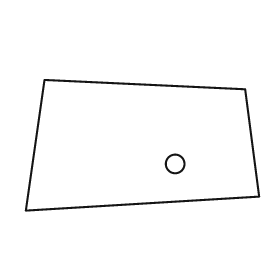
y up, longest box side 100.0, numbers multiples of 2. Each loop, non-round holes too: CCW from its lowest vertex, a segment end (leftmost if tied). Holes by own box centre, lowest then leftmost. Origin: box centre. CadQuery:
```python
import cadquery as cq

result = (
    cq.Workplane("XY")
    .moveTo(-50.0, -28.0)
    .lineTo(50.0, -22.0)
    .lineTo(44.0, 24.0)
    .lineTo(-42.0, 28.0)
    .close()
    .moveTo(14.0, -8.0)
    .circle(4.0)
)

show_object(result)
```